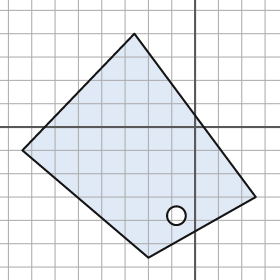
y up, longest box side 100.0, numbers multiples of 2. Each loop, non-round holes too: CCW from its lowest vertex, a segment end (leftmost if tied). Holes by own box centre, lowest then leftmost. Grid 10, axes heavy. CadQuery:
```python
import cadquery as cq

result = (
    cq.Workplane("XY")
    .moveTo(-20.0, -56.0)
    .lineTo(26.0, -30.0)
    .lineTo(-26.0, 40.0)
    .lineTo(-74.0, -10.0)
    .close()
    .moveTo(-8.0, -38.0)
    .circle(4.0)
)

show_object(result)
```